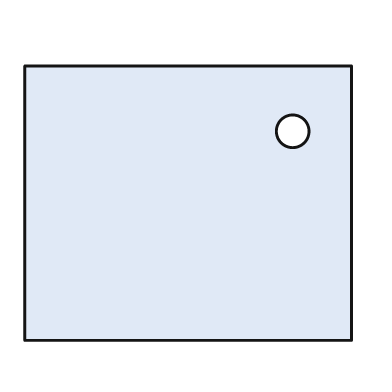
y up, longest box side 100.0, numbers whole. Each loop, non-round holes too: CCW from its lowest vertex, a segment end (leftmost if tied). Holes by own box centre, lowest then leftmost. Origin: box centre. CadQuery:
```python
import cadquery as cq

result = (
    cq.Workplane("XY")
    .moveTo(-50.0, -42.0)
    .lineTo(50.0, -42.0)
    .lineTo(50.0, 42.0)
    .lineTo(-50.0, 42.0)
    .close()
    .moveTo(32.0, 22.0)
    .circle(5.0)
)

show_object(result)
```